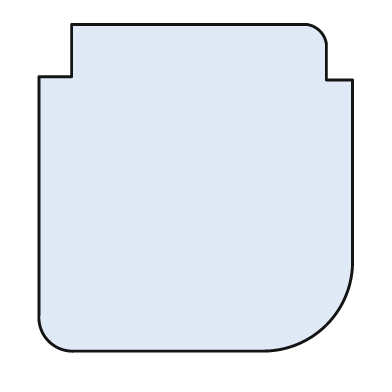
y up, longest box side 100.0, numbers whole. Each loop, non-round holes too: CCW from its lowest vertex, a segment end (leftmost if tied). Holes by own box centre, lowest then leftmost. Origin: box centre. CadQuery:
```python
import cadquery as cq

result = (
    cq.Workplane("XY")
    .moveTo(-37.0, -50.0)
    .lineTo(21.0, -50.0)
    .threePointArc((40.0, -42.0), (48.0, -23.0))
    .lineTo(48.0, 33.0)
    .lineTo(40.0, 33.0)
    .lineTo(40.0, 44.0)
    .threePointArc((38.0, 48.0), (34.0, 50.0))
    .lineTo(-38.0, 50.0)
    .lineTo(-38.0, 34.0)
    .lineTo(-48.0, 34.0)
    .lineTo(-48.0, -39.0)
    .threePointArc((-45.0, -47.0), (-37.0, -50.0))
    .close()
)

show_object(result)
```